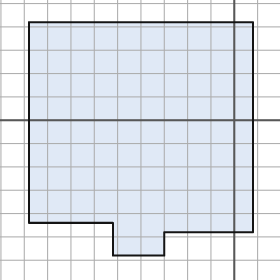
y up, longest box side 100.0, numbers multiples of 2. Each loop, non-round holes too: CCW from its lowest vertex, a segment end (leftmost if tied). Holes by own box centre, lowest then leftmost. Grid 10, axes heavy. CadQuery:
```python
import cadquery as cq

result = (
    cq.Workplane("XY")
    .moveTo(-52.0, -58.0)
    .lineTo(-30.0, -58.0)
    .lineTo(-30.0, -48.0)
    .lineTo(8.0, -48.0)
    .lineTo(8.0, 42.0)
    .lineTo(-88.0, 42.0)
    .lineTo(-88.0, -44.0)
    .lineTo(-52.0, -44.0)
    .close()
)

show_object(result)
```